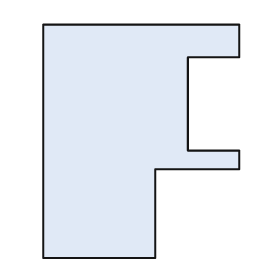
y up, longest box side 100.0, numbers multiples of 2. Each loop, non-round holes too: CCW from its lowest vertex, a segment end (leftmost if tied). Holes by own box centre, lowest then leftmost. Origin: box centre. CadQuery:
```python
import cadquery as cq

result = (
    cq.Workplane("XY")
    .moveTo(-42.0, -50.0)
    .lineTo(6.0, -50.0)
    .lineTo(6.0, -12.0)
    .lineTo(42.0, -12.0)
    .lineTo(42.0, -4.0)
    .lineTo(20.0, -4.0)
    .lineTo(20.0, 36.0)
    .lineTo(42.0, 36.0)
    .lineTo(42.0, 50.0)
    .lineTo(-42.0, 50.0)
    .close()
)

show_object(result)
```